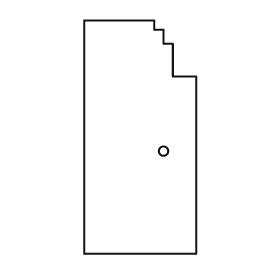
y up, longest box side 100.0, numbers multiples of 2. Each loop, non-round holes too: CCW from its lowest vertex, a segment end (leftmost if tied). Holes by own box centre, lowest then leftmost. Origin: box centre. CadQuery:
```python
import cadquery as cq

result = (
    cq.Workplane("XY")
    .moveTo(-24.0, -50.0)
    .lineTo(24.0, -50.0)
    .lineTo(24.0, 26.0)
    .lineTo(14.0, 26.0)
    .lineTo(14.0, 40.0)
    .lineTo(10.0, 40.0)
    .lineTo(10.0, 46.0)
    .lineTo(6.0, 46.0)
    .lineTo(6.0, 50.0)
    .lineTo(-24.0, 50.0)
    .close()
    .moveTo(10.0, -6.0)
    .circle(2.0)
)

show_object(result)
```